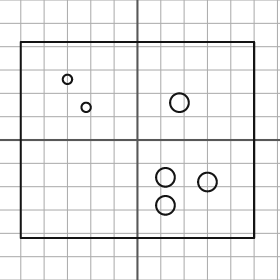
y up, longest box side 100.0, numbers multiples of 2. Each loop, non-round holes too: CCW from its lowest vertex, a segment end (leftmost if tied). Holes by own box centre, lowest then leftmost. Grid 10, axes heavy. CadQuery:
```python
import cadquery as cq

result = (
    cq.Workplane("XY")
    .moveTo(-50.0, -42.0)
    .lineTo(50.0, -42.0)
    .lineTo(50.0, 42.0)
    .lineTo(-50.0, 42.0)
    .close()
    .moveTo(12.0, -28.0)
    .circle(4.0)
    .moveTo(30.0, -18.0)
    .circle(4.0)
    .moveTo(12.0, -16.0)
    .circle(4.0)
    .moveTo(-22.0, 14.0)
    .circle(2.0)
    .moveTo(18.0, 16.0)
    .circle(4.0)
    .moveTo(-30.0, 26.0)
    .circle(2.0)
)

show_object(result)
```